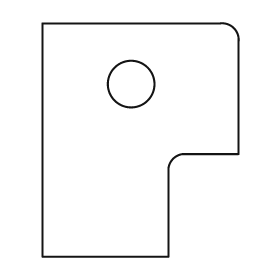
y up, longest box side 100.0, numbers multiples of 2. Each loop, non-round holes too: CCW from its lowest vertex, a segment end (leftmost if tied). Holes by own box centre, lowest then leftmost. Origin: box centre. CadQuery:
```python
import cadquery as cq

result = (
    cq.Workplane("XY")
    .moveTo(-42.0, -50.0)
    .lineTo(12.0, -50.0)
    .lineTo(12.0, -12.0)
    .threePointArc((14.0, -8.0), (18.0, -6.0))
    .lineTo(42.0, -6.0)
    .lineTo(42.0, 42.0)
    .threePointArc((40.0, 48.0), (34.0, 50.0))
    .lineTo(-42.0, 50.0)
    .close()
    .moveTo(-4.0, 24.0)
    .circle(10.0)
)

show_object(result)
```